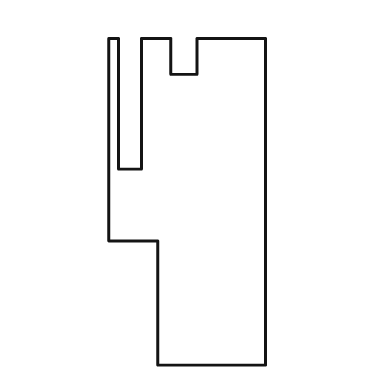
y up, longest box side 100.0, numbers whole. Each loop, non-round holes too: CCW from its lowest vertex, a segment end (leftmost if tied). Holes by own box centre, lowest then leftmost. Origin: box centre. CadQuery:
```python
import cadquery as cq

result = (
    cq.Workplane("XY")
    .moveTo(-9.0, -50.0)
    .lineTo(24.0, -50.0)
    .lineTo(24.0, 50.0)
    .lineTo(3.0, 50.0)
    .lineTo(3.0, 39.0)
    .lineTo(-5.0, 39.0)
    .lineTo(-5.0, 50.0)
    .lineTo(-14.0, 50.0)
    .lineTo(-14.0, 10.0)
    .lineTo(-21.0, 10.0)
    .lineTo(-21.0, 50.0)
    .lineTo(-24.0, 50.0)
    .lineTo(-24.0, -12.0)
    .lineTo(-9.0, -12.0)
    .close()
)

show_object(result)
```